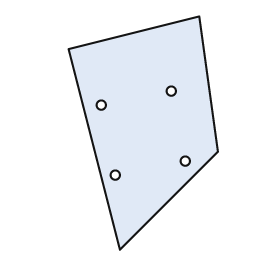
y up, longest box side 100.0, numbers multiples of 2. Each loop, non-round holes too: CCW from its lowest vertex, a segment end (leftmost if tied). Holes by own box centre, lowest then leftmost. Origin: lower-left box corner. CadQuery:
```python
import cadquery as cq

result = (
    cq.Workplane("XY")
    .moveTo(22.0, 0.0)
    .lineTo(64.0, 42.0)
    .lineTo(56.0, 100.0)
    .lineTo(0.0, 86.0)
    .close()
    .moveTo(20.0, 32.0)
    .circle(2.0)
    .moveTo(50.0, 38.0)
    .circle(2.0)
    .moveTo(14.0, 62.0)
    .circle(2.0)
    .moveTo(44.0, 68.0)
    .circle(2.0)
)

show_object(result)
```